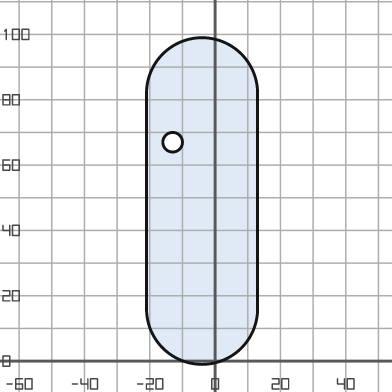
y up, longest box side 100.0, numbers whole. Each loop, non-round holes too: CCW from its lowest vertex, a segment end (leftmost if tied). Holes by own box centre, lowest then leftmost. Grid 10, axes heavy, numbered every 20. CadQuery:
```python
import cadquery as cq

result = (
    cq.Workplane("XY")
    .moveTo(-21.0, 16.0)
    .threePointArc((-4.0, -1.0), (13.0, 16.0))
    .lineTo(13.0, 82.0)
    .threePointArc((-4.0, 99.0), (-21.0, 82.0))
    .close()
    .moveTo(-13.0, 67.0)
    .circle(3.0)
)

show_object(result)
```